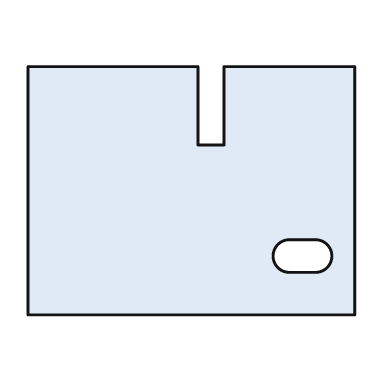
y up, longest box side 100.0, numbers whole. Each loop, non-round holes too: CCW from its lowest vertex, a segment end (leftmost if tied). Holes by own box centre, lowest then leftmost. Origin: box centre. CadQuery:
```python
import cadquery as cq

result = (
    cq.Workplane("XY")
    .moveTo(-50.0, -38.0)
    .lineTo(50.0, -38.0)
    .lineTo(50.0, 38.0)
    .lineTo(10.0, 38.0)
    .lineTo(10.0, 14.0)
    .lineTo(2.0, 14.0)
    .lineTo(2.0, 38.0)
    .lineTo(-50.0, 38.0)
    .close()
    .moveTo(30.0, -25.0)
    .lineTo(38.0, -25.0)
    .threePointArc((43.0, -20.0), (38.0, -15.0))
    .lineTo(30.0, -15.0)
    .threePointArc((25.0, -20.0), (30.0, -25.0))
    .close()
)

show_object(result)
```